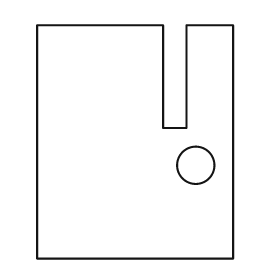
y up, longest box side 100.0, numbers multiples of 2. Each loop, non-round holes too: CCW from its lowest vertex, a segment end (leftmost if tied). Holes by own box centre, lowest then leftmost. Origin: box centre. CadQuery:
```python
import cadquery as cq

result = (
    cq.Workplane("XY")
    .moveTo(-42.0, -50.0)
    .lineTo(42.0, -50.0)
    .lineTo(42.0, 50.0)
    .lineTo(22.0, 50.0)
    .lineTo(22.0, 6.0)
    .lineTo(12.0, 6.0)
    .lineTo(12.0, 50.0)
    .lineTo(-42.0, 50.0)
    .close()
    .moveTo(26.0, -10.0)
    .circle(8.0)
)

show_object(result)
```